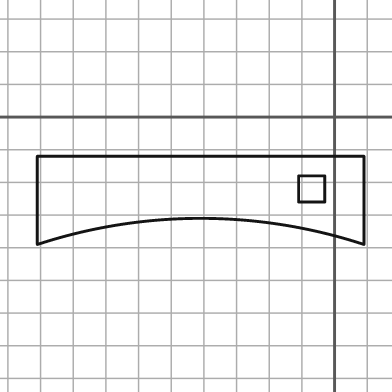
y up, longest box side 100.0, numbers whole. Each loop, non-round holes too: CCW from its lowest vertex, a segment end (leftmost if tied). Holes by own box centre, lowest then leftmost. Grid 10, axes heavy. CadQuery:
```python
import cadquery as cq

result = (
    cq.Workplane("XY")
    .moveTo(-91.0, -39.0)
    .threePointArc((-41.0, -31.0), (9.0, -39.0))
    .lineTo(9.0, -12.0)
    .lineTo(-91.0, -12.0)
    .close()
    .moveTo(-11.0, -26.0)
    .lineTo(-3.0, -26.0)
    .lineTo(-3.0, -18.0)
    .lineTo(-11.0, -18.0)
    .close()
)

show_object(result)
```